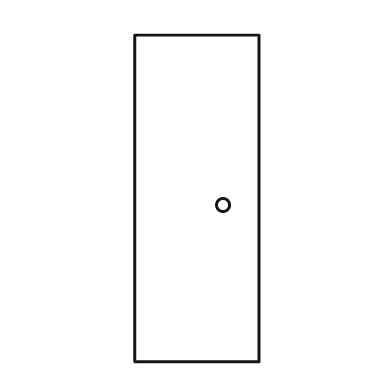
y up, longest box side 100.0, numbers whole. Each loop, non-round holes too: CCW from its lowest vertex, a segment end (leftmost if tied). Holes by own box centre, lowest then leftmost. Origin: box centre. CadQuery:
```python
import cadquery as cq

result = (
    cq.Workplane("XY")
    .moveTo(-19.0, -50.0)
    .lineTo(19.0, -50.0)
    .lineTo(19.0, 50.0)
    .lineTo(-19.0, 50.0)
    .close()
    .moveTo(8.0, -2.0)
    .circle(2.0)
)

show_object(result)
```